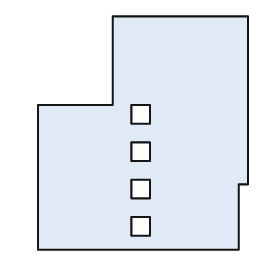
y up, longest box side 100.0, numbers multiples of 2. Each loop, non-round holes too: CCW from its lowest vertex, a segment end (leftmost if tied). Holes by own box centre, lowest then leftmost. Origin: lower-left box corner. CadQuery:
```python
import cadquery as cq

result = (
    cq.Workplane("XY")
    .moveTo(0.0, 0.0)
    .lineTo(86.0, 0.0)
    .lineTo(86.0, 28.0)
    .lineTo(90.0, 28.0)
    .lineTo(90.0, 100.0)
    .lineTo(32.0, 100.0)
    .lineTo(32.0, 62.0)
    .lineTo(0.0, 62.0)
    .close()
    .moveTo(40.0, 6.0)
    .lineTo(48.0, 6.0)
    .lineTo(48.0, 14.0)
    .lineTo(40.0, 14.0)
    .close()
    .moveTo(40.0, 22.0)
    .lineTo(48.0, 22.0)
    .lineTo(48.0, 30.0)
    .lineTo(40.0, 30.0)
    .close()
    .moveTo(40.0, 38.0)
    .lineTo(48.0, 38.0)
    .lineTo(48.0, 46.0)
    .lineTo(40.0, 46.0)
    .close()
    .moveTo(40.0, 54.0)
    .lineTo(48.0, 54.0)
    .lineTo(48.0, 62.0)
    .lineTo(40.0, 62.0)
    .close()
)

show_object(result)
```